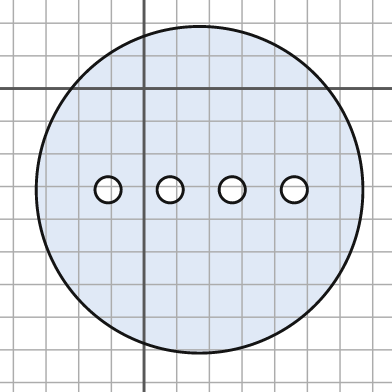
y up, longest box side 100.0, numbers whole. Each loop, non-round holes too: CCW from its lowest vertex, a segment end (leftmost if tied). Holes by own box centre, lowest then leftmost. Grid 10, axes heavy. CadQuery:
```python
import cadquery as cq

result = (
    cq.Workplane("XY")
    .moveTo(17.0, -31.0)
    .circle(50.0)
    .moveTo(-11.0, -31.0)
    .circle(4.0)
    .moveTo(8.0, -31.0)
    .circle(4.0)
    .moveTo(27.0, -31.0)
    .circle(4.0)
    .moveTo(46.0, -31.0)
    .circle(4.0)
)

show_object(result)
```